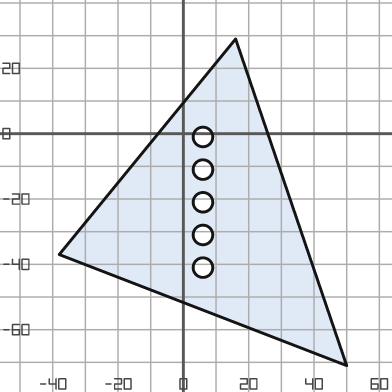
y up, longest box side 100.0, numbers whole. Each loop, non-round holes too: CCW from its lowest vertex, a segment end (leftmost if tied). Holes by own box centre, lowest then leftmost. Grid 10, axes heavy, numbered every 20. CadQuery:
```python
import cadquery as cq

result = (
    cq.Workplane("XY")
    .moveTo(50.0, -71.0)
    .lineTo(16.0, 29.0)
    .lineTo(-38.0, -37.0)
    .close()
    .moveTo(6.0, -41.0)
    .circle(3.0)
    .moveTo(6.0, -31.0)
    .circle(3.0)
    .moveTo(6.0, -21.0)
    .circle(3.0)
    .moveTo(6.0, -11.0)
    .circle(3.0)
    .moveTo(6.0, -1.0)
    .circle(3.0)
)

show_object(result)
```